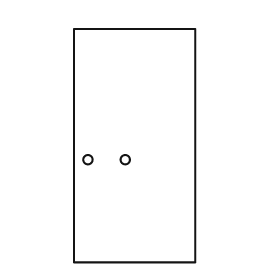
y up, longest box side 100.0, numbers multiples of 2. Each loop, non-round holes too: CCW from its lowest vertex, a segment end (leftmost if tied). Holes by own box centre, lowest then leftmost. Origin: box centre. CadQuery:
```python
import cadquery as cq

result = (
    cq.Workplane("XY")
    .moveTo(-26.0, -50.0)
    .lineTo(26.0, -50.0)
    .lineTo(26.0, 50.0)
    .lineTo(-26.0, 50.0)
    .close()
    .moveTo(-20.0, -6.0)
    .circle(2.0)
    .moveTo(-4.0, -6.0)
    .circle(2.0)
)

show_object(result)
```